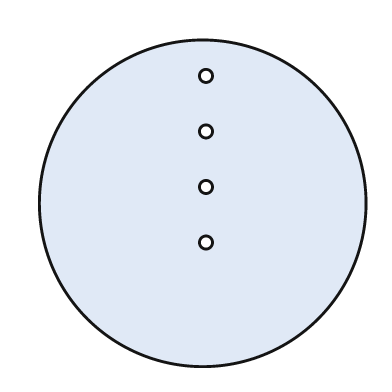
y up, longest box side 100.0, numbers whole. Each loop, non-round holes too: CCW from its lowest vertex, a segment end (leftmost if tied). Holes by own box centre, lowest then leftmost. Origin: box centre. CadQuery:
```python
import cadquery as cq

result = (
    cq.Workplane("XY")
    .moveTo(0.0, 0.0)
    .circle(50.0)
    .moveTo(1.0, -12.0)
    .circle(2.0)
    .moveTo(1.0, 5.0)
    .circle(2.0)
    .moveTo(1.0, 22.0)
    .circle(2.0)
    .moveTo(1.0, 39.0)
    .circle(2.0)
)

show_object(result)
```